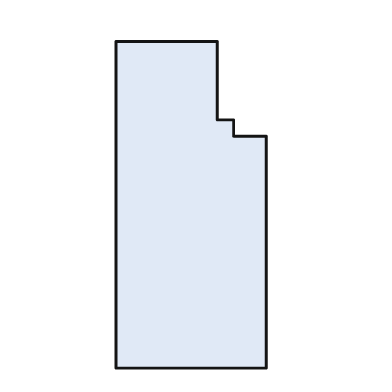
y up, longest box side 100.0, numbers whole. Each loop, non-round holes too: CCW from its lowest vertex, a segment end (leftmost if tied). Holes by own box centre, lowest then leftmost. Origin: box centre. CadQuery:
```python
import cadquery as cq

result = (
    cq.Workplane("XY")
    .moveTo(-23.0, -50.0)
    .lineTo(23.0, -50.0)
    .lineTo(23.0, 21.0)
    .lineTo(13.0, 21.0)
    .lineTo(13.0, 26.0)
    .lineTo(8.0, 26.0)
    .lineTo(8.0, 50.0)
    .lineTo(-23.0, 50.0)
    .close()
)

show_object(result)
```